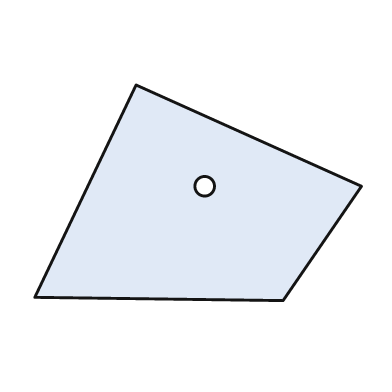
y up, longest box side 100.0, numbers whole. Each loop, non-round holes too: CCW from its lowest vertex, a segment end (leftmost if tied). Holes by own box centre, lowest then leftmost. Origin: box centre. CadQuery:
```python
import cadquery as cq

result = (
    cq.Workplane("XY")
    .moveTo(26.0, -33.0)
    .lineTo(50.0, 2.0)
    .lineTo(-19.0, 33.0)
    .lineTo(-50.0, -32.0)
    .close()
    .moveTo(2.0, 2.0)
    .circle(3.0)
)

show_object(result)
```